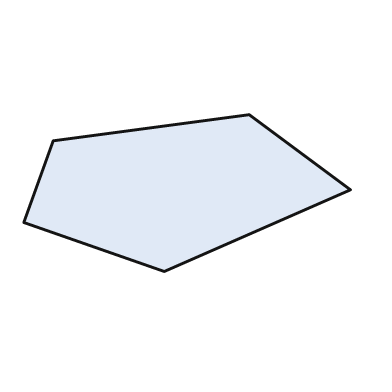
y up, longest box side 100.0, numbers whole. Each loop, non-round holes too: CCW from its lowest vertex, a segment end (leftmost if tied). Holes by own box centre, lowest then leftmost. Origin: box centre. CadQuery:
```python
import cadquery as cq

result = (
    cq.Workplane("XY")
    .moveTo(-7.0, -24.0)
    .lineTo(50.0, 1.0)
    .lineTo(19.0, 24.0)
    .lineTo(-41.0, 16.0)
    .lineTo(-50.0, -9.0)
    .close()
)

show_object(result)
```